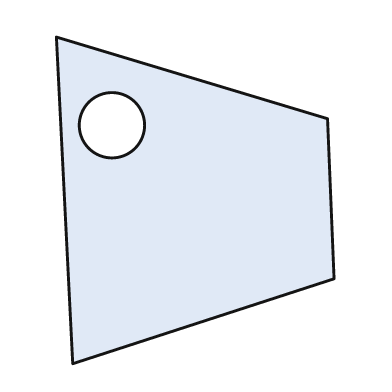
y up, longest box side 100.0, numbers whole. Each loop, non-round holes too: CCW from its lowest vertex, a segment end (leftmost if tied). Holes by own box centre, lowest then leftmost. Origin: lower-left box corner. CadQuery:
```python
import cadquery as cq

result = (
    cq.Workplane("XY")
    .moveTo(5.0, 0.0)
    .lineTo(85.0, 26.0)
    .lineTo(83.0, 75.0)
    .lineTo(0.0, 100.0)
    .close()
    .moveTo(17.0, 73.0)
    .circle(10.0)
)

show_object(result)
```